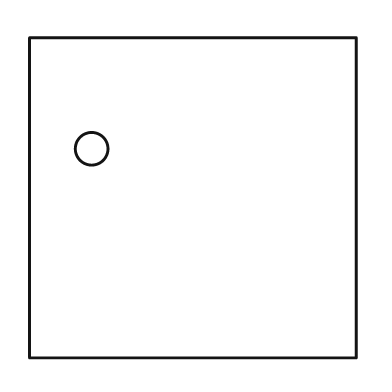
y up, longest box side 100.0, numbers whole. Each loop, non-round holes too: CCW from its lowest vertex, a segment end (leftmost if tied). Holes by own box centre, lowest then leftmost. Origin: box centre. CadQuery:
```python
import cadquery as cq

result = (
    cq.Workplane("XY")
    .moveTo(-50.0, -49.0)
    .lineTo(50.0, -49.0)
    .lineTo(50.0, 49.0)
    .lineTo(-50.0, 49.0)
    .close()
    .moveTo(-31.0, 15.0)
    .circle(5.0)
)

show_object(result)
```